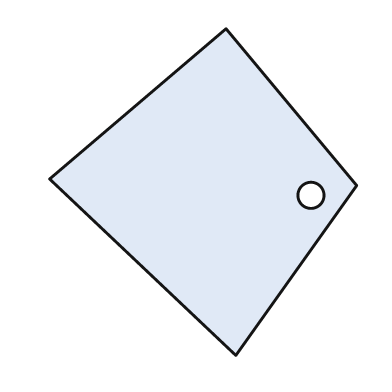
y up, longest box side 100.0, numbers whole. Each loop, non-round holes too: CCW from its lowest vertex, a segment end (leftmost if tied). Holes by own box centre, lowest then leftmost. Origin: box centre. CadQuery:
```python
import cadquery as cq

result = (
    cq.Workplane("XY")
    .moveTo(10.0, -50.0)
    .lineTo(47.0, 2.0)
    .lineTo(7.0, 50.0)
    .lineTo(-47.0, 4.0)
    .close()
    .moveTo(33.0, -1.0)
    .circle(4.0)
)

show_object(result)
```